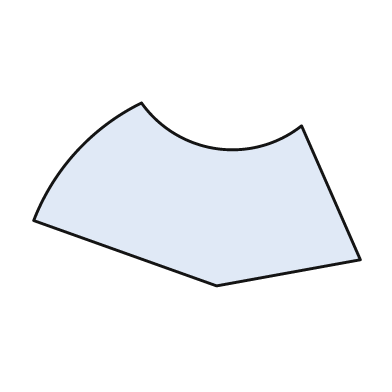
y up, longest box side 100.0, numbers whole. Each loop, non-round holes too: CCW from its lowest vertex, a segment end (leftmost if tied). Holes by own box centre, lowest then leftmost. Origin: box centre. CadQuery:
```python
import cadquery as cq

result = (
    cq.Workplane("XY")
    .moveTo(6.0, -28.0)
    .lineTo(50.0, -20.0)
    .lineTo(32.0, 21.0)
    .threePointArc((6.0, 14.0), (-17.0, 28.0))
    .threePointArc((-37.0, 13.0), (-50.0, -8.0))
    .close()
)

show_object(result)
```